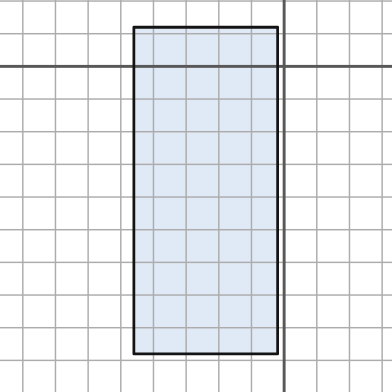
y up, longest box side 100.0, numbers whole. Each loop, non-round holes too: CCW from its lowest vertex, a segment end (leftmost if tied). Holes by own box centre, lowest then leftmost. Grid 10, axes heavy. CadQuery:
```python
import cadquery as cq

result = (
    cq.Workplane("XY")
    .moveTo(-46.0, -88.0)
    .lineTo(-2.0, -88.0)
    .lineTo(-2.0, 12.0)
    .lineTo(-46.0, 12.0)
    .close()
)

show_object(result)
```